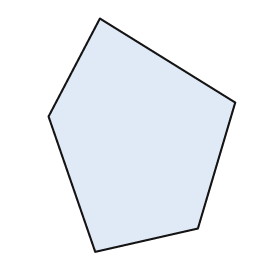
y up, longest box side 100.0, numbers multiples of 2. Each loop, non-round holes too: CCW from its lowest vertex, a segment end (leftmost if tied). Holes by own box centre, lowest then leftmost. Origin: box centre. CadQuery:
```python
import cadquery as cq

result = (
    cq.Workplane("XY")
    .moveTo(-20.0, -50.0)
    .lineTo(24.0, -40.0)
    .lineTo(40.0, 14.0)
    .lineTo(-18.0, 50.0)
    .lineTo(-40.0, 8.0)
    .close()
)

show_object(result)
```